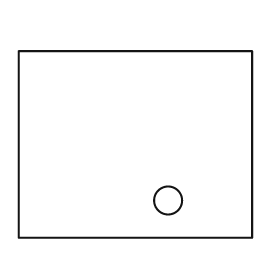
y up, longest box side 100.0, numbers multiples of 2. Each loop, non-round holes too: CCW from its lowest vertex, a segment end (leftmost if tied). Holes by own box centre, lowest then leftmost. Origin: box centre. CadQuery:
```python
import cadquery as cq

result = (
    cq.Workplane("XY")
    .moveTo(-50.0, -40.0)
    .lineTo(50.0, -40.0)
    .lineTo(50.0, 40.0)
    .lineTo(-50.0, 40.0)
    .close()
    .moveTo(14.0, -24.0)
    .circle(6.0)
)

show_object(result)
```